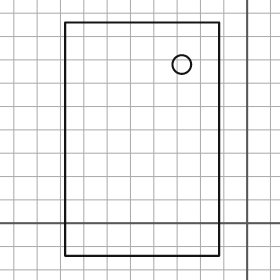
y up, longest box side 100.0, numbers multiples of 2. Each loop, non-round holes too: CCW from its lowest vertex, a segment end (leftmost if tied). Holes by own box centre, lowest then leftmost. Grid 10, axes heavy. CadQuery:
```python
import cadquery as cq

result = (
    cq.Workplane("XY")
    .moveTo(-78.0, -14.0)
    .lineTo(-12.0, -14.0)
    .lineTo(-12.0, 86.0)
    .lineTo(-78.0, 86.0)
    .close()
    .moveTo(-28.0, 68.0)
    .circle(4.0)
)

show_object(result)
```